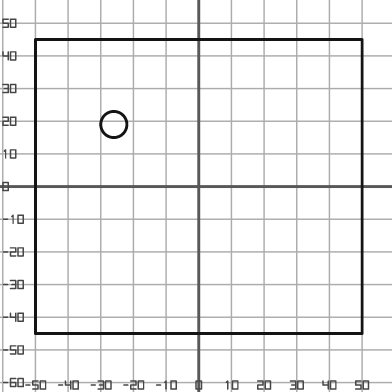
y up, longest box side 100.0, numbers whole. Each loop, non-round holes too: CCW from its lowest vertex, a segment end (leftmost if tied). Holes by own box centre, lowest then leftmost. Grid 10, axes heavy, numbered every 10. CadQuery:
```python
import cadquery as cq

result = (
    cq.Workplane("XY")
    .moveTo(-50.0, -45.0)
    .lineTo(50.0, -45.0)
    .lineTo(50.0, 45.0)
    .lineTo(-50.0, 45.0)
    .close()
    .moveTo(-26.0, 19.0)
    .circle(4.0)
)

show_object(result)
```